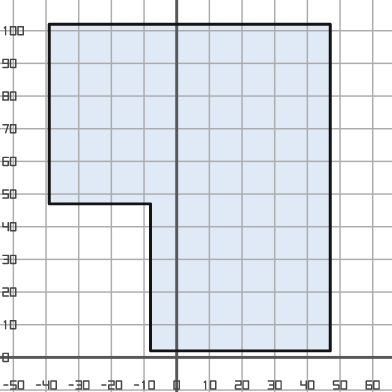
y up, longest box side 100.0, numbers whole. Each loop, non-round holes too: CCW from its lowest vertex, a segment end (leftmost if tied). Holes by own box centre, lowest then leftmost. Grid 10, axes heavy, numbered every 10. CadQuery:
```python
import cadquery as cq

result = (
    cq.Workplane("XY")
    .moveTo(-8.0, 2.0)
    .lineTo(47.0, 2.0)
    .lineTo(47.0, 102.0)
    .lineTo(-39.0, 102.0)
    .lineTo(-39.0, 47.0)
    .lineTo(-8.0, 47.0)
    .close()
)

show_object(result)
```